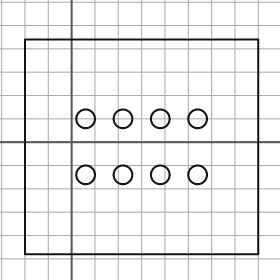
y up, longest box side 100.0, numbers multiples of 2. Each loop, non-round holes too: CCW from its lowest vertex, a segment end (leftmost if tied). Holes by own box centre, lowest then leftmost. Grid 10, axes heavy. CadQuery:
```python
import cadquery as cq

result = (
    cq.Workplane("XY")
    .moveTo(-20.0, -48.0)
    .lineTo(80.0, -48.0)
    .lineTo(80.0, 44.0)
    .lineTo(-20.0, 44.0)
    .close()
    .moveTo(6.0, -14.0)
    .circle(4.0)
    .moveTo(22.0, -14.0)
    .circle(4.0)
    .moveTo(38.0, -14.0)
    .circle(4.0)
    .moveTo(54.0, -14.0)
    .circle(4.0)
    .moveTo(6.0, 10.0)
    .circle(4.0)
    .moveTo(22.0, 10.0)
    .circle(4.0)
    .moveTo(38.0, 10.0)
    .circle(4.0)
    .moveTo(54.0, 10.0)
    .circle(4.0)
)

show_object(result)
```